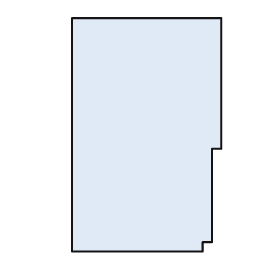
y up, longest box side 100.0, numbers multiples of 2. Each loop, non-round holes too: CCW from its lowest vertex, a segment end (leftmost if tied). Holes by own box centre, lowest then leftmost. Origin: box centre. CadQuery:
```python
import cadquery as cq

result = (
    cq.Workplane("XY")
    .moveTo(-32.0, -50.0)
    .lineTo(24.0, -50.0)
    .lineTo(24.0, -46.0)
    .lineTo(28.0, -46.0)
    .lineTo(28.0, -6.0)
    .lineTo(32.0, -6.0)
    .lineTo(32.0, 50.0)
    .lineTo(-32.0, 50.0)
    .close()
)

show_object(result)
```